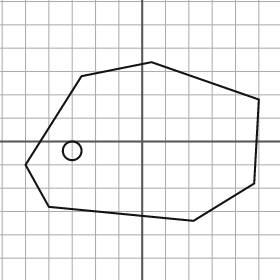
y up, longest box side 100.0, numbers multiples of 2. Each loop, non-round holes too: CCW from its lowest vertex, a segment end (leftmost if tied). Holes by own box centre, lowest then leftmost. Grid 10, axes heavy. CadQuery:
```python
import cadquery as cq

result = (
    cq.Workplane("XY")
    .moveTo(22.0, -34.0)
    .lineTo(48.0, -18.0)
    .lineTo(50.0, 18.0)
    .lineTo(4.0, 34.0)
    .lineTo(-26.0, 28.0)
    .lineTo(-50.0, -10.0)
    .lineTo(-40.0, -28.0)
    .close()
    .moveTo(-30.0, -4.0)
    .circle(4.0)
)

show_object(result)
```